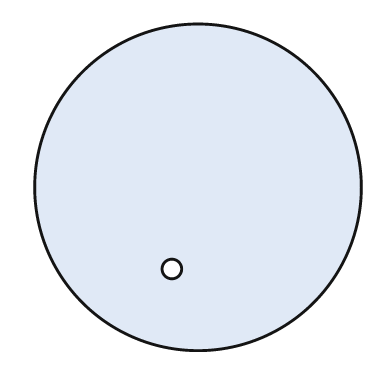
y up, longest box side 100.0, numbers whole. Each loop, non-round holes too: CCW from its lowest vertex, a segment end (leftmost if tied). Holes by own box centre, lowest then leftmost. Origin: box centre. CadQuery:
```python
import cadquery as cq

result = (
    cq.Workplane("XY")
    .moveTo(0.0, 0.0)
    .circle(50.0)
    .moveTo(-8.0, -25.0)
    .circle(3.0)
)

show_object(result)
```